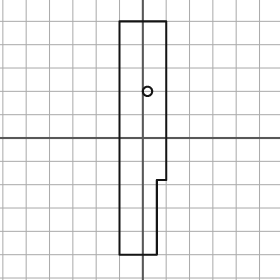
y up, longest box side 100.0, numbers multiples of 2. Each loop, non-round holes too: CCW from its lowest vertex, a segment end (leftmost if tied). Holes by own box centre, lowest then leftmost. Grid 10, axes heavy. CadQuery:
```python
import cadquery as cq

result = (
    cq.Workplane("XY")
    .moveTo(-10.0, -50.0)
    .lineTo(6.0, -50.0)
    .lineTo(6.0, -18.0)
    .lineTo(10.0, -18.0)
    .lineTo(10.0, 50.0)
    .lineTo(-10.0, 50.0)
    .close()
    .moveTo(2.0, 20.0)
    .circle(2.0)
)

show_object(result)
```